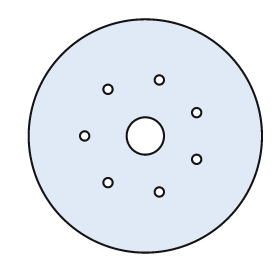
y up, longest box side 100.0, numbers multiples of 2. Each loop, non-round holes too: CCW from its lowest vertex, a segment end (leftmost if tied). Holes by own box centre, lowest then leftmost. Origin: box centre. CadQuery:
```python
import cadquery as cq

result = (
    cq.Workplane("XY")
    .moveTo(0.0, 0.0)
    .circle(50.0)
    .moveTo(6.0, -24.0)
    .circle(2.0)
    .moveTo(-16.0, -20.0)
    .circle(2.0)
    .moveTo(22.0, -10.0)
    .circle(2.0)
    .moveTo(-26.0, 0.0)
    .circle(2.0)
    .moveTo(0.0, 0.0)
    .circle(8.0)
    .moveTo(22.0, 10.0)
    .circle(2.0)
    .moveTo(-16.0, 20.0)
    .circle(2.0)
    .moveTo(6.0, 24.0)
    .circle(2.0)
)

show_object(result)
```